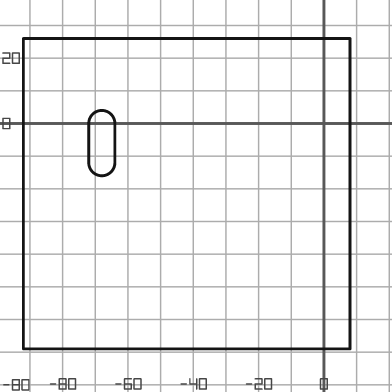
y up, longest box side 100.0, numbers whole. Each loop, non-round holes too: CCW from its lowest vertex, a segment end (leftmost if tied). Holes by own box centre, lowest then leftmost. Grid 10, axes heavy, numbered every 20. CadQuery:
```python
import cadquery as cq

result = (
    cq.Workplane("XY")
    .moveTo(-92.0, -69.0)
    .lineTo(8.0, -69.0)
    .lineTo(8.0, 26.0)
    .lineTo(-92.0, 26.0)
    .close()
    .moveTo(-72.0, -12.0)
    .threePointArc((-68.0, -16.0), (-64.0, -12.0))
    .lineTo(-64.0, 0.0)
    .threePointArc((-68.0, 4.0), (-72.0, 0.0))
    .close()
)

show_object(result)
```